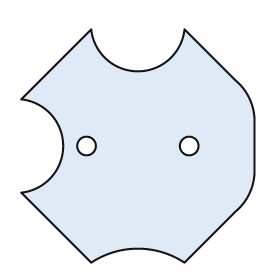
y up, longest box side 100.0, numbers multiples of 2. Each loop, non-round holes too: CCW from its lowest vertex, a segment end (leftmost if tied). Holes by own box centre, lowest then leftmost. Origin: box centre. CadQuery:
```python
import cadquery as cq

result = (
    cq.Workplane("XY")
    .moveTo(-20.0, -50.0)
    .threePointArc((0.0, -44.0), (20.0, -50.0))
    .lineTo(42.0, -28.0)
    .threePointArc((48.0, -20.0), (50.0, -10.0))
    .lineTo(50.0, 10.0)
    .threePointArc((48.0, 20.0), (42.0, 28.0))
    .lineTo(20.0, 50.0)
    .threePointArc((0.0, 32.0), (-20.0, 50.0))
    .lineTo(-50.0, 20.0)
    .threePointArc((-32.0, 0.0), (-50.0, -20.0))
    .close()
    .moveTo(-22.0, 0.0)
    .circle(4.0)
    .moveTo(22.0, 0.0)
    .circle(4.0)
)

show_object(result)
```